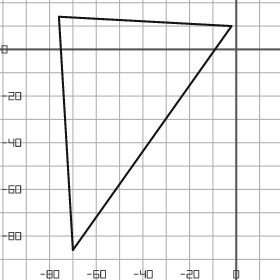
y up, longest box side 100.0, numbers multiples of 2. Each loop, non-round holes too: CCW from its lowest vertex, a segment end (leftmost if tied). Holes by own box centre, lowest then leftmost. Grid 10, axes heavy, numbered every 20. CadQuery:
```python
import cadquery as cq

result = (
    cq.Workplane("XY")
    .moveTo(-70.0, -86.0)
    .lineTo(-2.0, 10.0)
    .lineTo(-76.0, 14.0)
    .close()
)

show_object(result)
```